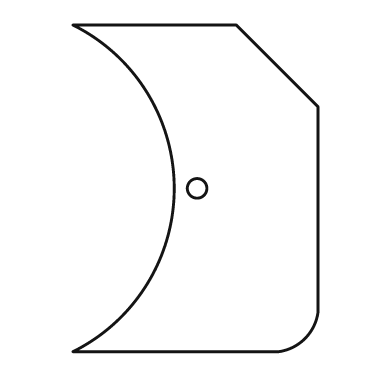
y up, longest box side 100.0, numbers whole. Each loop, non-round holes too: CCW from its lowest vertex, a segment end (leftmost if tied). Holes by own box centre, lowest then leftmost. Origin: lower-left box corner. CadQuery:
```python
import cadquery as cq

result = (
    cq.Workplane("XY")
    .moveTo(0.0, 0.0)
    .lineTo(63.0, 0.0)
    .threePointArc((71.0, 4.0), (75.0, 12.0))
    .lineTo(75.0, 75.0)
    .lineTo(50.0, 100.0)
    .lineTo(0.0, 100.0)
    .threePointArc((31.0, 50.0), (0.0, 0.0))
    .close()
    .moveTo(38.0, 50.0)
    .circle(3.0)
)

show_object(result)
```